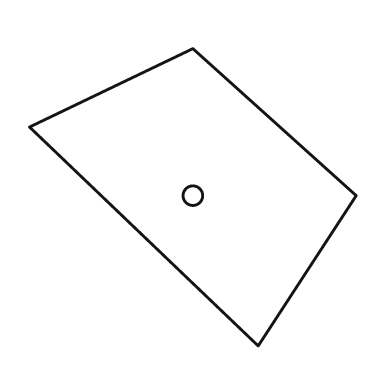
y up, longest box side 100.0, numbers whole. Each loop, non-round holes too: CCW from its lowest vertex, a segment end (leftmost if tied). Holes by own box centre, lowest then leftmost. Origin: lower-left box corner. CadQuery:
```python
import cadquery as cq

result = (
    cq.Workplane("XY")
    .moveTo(70.0, 0.0)
    .lineTo(100.0, 46.0)
    .lineTo(50.0, 91.0)
    .lineTo(0.0, 67.0)
    .close()
    .moveTo(50.0, 46.0)
    .circle(3.0)
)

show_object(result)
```